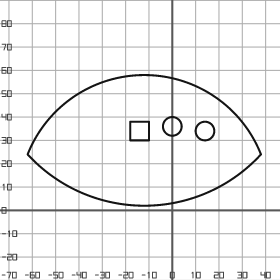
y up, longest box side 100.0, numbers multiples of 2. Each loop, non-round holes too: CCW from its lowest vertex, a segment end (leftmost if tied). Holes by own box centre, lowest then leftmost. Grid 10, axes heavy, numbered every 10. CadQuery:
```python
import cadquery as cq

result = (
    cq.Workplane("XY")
    .moveTo(-62.0, 24.0)
    .threePointArc((-12.0, 2.0), (38.0, 24.0))
    .threePointArc((-12.0, 58.0), (-62.0, 24.0))
    .close()
    .moveTo(-18.0, 30.0)
    .lineTo(-10.0, 30.0)
    .lineTo(-10.0, 38.0)
    .lineTo(-18.0, 38.0)
    .close()
    .moveTo(14.0, 34.0)
    .circle(4.0)
    .moveTo(0.0, 36.0)
    .circle(4.0)
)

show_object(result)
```